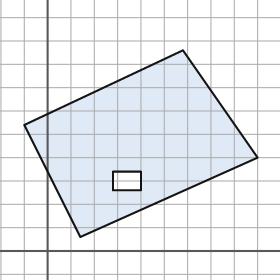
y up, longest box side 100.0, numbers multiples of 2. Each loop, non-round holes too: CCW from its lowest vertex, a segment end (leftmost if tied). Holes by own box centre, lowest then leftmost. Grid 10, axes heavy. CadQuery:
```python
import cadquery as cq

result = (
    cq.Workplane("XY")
    .moveTo(14.0, 6.0)
    .lineTo(90.0, 40.0)
    .lineTo(58.0, 86.0)
    .lineTo(-10.0, 54.0)
    .close()
    .moveTo(28.0, 26.0)
    .lineTo(40.0, 26.0)
    .lineTo(40.0, 34.0)
    .lineTo(28.0, 34.0)
    .close()
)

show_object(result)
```